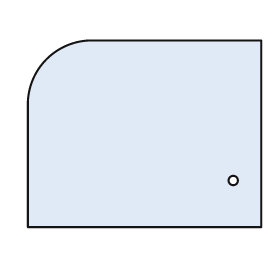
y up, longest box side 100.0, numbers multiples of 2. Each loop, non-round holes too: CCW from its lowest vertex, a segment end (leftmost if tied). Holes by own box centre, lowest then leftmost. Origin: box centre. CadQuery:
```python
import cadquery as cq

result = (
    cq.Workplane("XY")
    .moveTo(-50.0, -40.0)
    .lineTo(50.0, -40.0)
    .lineTo(50.0, 40.0)
    .lineTo(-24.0, 40.0)
    .threePointArc((-42.0, 32.0), (-50.0, 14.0))
    .close()
    .moveTo(38.0, -20.0)
    .circle(2.0)
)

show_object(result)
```